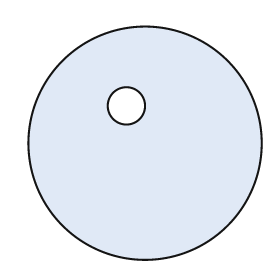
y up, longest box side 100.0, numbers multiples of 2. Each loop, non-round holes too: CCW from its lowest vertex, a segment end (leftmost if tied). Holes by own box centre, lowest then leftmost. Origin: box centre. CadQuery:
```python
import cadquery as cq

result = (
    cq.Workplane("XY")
    .moveTo(0.0, 0.0)
    .circle(50.0)
    .moveTo(-8.0, 16.0)
    .circle(8.0)
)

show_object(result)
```